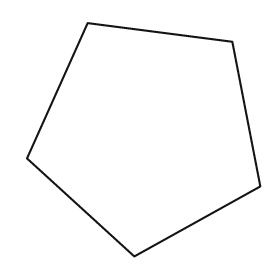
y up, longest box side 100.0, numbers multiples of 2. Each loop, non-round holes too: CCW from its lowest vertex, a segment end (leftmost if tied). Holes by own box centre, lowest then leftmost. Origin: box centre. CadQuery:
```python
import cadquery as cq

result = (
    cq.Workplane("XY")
    .moveTo(-4.0, -50.0)
    .lineTo(50.0, -20.0)
    .lineTo(38.0, 42.0)
    .lineTo(-24.0, 50.0)
    .lineTo(-50.0, -8.0)
    .close()
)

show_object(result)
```